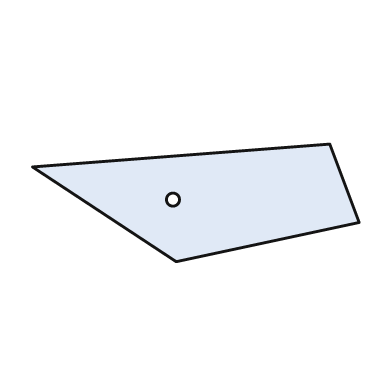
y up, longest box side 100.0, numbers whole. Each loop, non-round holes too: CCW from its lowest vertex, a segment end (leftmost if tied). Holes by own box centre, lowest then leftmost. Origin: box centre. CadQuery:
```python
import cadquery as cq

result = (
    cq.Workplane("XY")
    .moveTo(-6.0, -18.0)
    .lineTo(50.0, -6.0)
    .lineTo(41.0, 18.0)
    .lineTo(-50.0, 11.0)
    .close()
    .moveTo(-7.0, 1.0)
    .circle(2.0)
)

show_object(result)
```